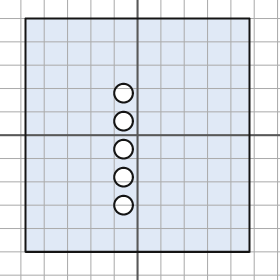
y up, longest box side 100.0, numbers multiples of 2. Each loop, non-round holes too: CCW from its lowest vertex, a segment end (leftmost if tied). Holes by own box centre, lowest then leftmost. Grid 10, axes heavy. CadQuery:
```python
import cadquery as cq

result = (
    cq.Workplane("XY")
    .moveTo(-48.0, -50.0)
    .lineTo(48.0, -50.0)
    .lineTo(48.0, 50.0)
    .lineTo(-48.0, 50.0)
    .close()
    .moveTo(-6.0, -30.0)
    .circle(4.0)
    .moveTo(-6.0, -18.0)
    .circle(4.0)
    .moveTo(-6.0, -6.0)
    .circle(4.0)
    .moveTo(-6.0, 6.0)
    .circle(4.0)
    .moveTo(-6.0, 18.0)
    .circle(4.0)
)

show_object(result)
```